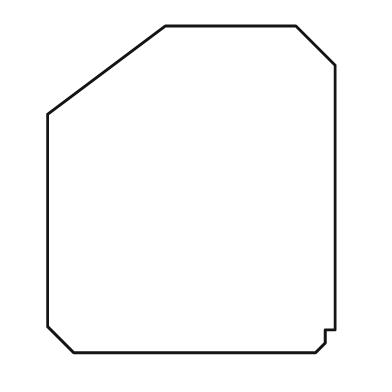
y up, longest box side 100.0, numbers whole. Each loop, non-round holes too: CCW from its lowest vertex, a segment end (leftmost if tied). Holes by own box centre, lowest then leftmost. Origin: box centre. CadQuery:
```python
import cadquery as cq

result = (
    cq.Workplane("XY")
    .moveTo(-36.0, -50.0)
    .lineTo(38.0, -50.0)
    .lineTo(41.0, -47.0)
    .lineTo(41.0, -43.0)
    .lineTo(44.0, -43.0)
    .lineTo(44.0, 38.0)
    .lineTo(32.0, 50.0)
    .lineTo(-8.0, 50.0)
    .lineTo(-44.0, 23.0)
    .lineTo(-44.0, -42.0)
    .close()
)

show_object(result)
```